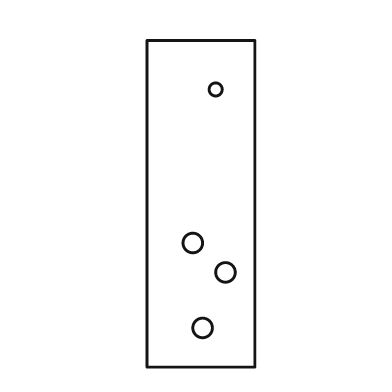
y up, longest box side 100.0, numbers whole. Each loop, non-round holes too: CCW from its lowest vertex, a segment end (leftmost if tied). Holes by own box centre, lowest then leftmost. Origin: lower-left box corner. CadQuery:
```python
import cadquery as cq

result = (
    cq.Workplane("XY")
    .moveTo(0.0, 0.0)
    .lineTo(33.0, 0.0)
    .lineTo(33.0, 100.0)
    .lineTo(0.0, 100.0)
    .close()
    .moveTo(17.0, 12.0)
    .circle(3.0)
    .moveTo(24.0, 29.0)
    .circle(3.0)
    .moveTo(14.0, 38.0)
    .circle(3.0)
    .moveTo(21.0, 85.0)
    .circle(2.0)
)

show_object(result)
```